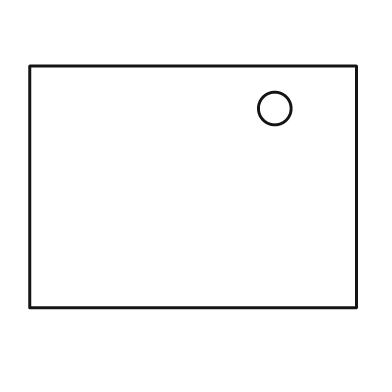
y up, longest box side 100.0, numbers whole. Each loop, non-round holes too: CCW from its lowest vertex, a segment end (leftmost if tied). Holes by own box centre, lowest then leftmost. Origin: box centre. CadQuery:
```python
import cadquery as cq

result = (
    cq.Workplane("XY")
    .moveTo(-50.0, -37.0)
    .lineTo(50.0, -37.0)
    .lineTo(50.0, 37.0)
    .lineTo(-50.0, 37.0)
    .close()
    .moveTo(25.0, 24.0)
    .circle(5.0)
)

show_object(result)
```